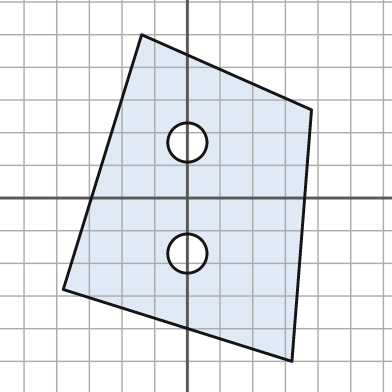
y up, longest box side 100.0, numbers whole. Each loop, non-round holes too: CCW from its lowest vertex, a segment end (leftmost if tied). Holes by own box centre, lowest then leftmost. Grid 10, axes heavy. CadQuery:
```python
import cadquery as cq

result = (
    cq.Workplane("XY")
    .moveTo(32.0, -50.0)
    .lineTo(38.0, 27.0)
    .lineTo(-14.0, 50.0)
    .lineTo(-38.0, -28.0)
    .close()
    .moveTo(0.0, -17.0)
    .circle(6.0)
    .moveTo(0.0, 17.0)
    .circle(6.0)
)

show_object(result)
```